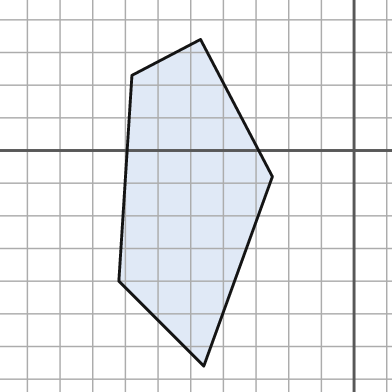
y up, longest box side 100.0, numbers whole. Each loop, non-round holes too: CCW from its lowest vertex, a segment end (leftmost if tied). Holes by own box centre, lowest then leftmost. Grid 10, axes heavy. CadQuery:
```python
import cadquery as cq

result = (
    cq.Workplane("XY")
    .moveTo(-46.0, -66.0)
    .lineTo(-25.0, -8.0)
    .lineTo(-47.0, 34.0)
    .lineTo(-68.0, 23.0)
    .lineTo(-72.0, -40.0)
    .close()
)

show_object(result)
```